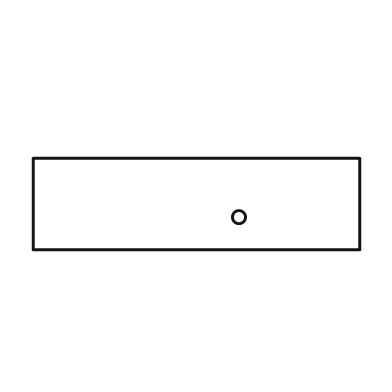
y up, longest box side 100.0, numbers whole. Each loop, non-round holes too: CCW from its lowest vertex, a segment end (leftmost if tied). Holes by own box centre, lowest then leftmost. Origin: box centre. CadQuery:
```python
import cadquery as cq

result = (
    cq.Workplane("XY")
    .moveTo(-50.0, -14.0)
    .lineTo(50.0, -14.0)
    .lineTo(50.0, 14.0)
    .lineTo(-50.0, 14.0)
    .close()
    .moveTo(13.0, -4.0)
    .circle(2.0)
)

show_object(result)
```